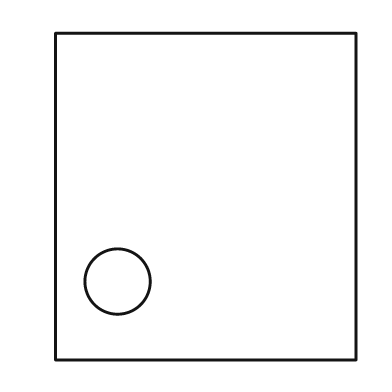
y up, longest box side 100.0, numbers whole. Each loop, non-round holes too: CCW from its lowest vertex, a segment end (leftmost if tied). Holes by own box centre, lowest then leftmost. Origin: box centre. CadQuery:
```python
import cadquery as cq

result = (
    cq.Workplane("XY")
    .moveTo(-46.0, -50.0)
    .lineTo(46.0, -50.0)
    .lineTo(46.0, 50.0)
    .lineTo(-46.0, 50.0)
    .close()
    .moveTo(-27.0, -26.0)
    .circle(10.0)
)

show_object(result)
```